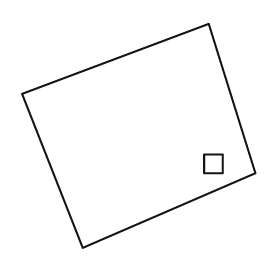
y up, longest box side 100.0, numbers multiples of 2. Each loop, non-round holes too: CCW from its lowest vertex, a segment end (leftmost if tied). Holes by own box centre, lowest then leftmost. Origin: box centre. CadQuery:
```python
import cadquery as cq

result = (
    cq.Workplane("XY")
    .moveTo(-24.0, -48.0)
    .lineTo(50.0, -16.0)
    .lineTo(30.0, 48.0)
    .lineTo(-50.0, 18.0)
    .close()
    .moveTo(28.0, -16.0)
    .lineTo(36.0, -16.0)
    .lineTo(36.0, -8.0)
    .lineTo(28.0, -8.0)
    .close()
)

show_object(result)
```